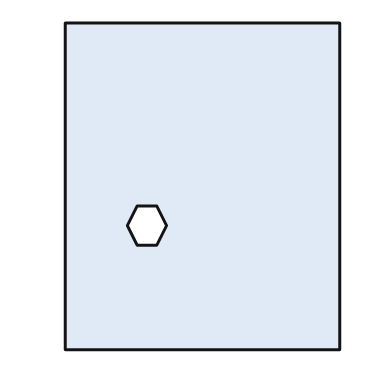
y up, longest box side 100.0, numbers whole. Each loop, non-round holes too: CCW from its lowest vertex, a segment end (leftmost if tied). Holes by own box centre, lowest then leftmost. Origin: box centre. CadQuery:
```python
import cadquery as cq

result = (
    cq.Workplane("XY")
    .moveTo(-42.0, -50.0)
    .lineTo(42.0, -50.0)
    .lineTo(42.0, 50.0)
    .lineTo(-42.0, 50.0)
    .close()
    .moveTo(-20.0, -18.0)
    .lineTo(-14.0, -18.0)
    .lineTo(-11.0, -12.0)
    .lineTo(-14.0, -6.0)
    .lineTo(-20.0, -6.0)
    .lineTo(-23.0, -12.0)
    .close()
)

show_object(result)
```